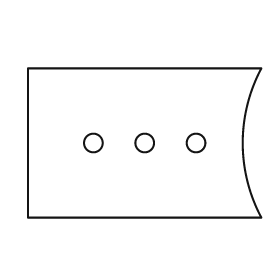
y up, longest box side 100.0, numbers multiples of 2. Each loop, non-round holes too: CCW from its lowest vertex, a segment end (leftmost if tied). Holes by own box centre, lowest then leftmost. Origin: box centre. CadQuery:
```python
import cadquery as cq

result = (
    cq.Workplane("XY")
    .moveTo(-50.0, -32.0)
    .lineTo(50.0, -32.0)
    .threePointArc((42.0, 0.0), (50.0, 32.0))
    .lineTo(-50.0, 32.0)
    .close()
    .moveTo(-22.0, 0.0)
    .circle(4.0)
    .moveTo(0.0, 0.0)
    .circle(4.0)
    .moveTo(22.0, 0.0)
    .circle(4.0)
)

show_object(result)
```